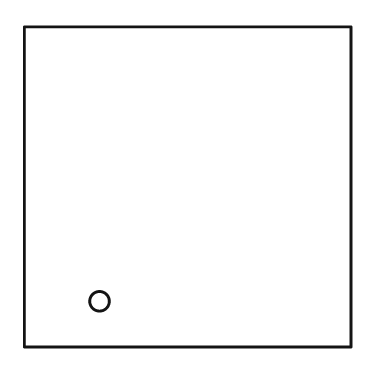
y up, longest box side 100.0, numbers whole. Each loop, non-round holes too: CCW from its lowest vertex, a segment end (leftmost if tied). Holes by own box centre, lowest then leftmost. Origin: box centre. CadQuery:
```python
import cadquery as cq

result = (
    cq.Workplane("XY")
    .moveTo(-50.0, -49.0)
    .lineTo(50.0, -49.0)
    .lineTo(50.0, 49.0)
    .lineTo(-50.0, 49.0)
    .close()
    .moveTo(-27.0, -35.0)
    .circle(3.0)
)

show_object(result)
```